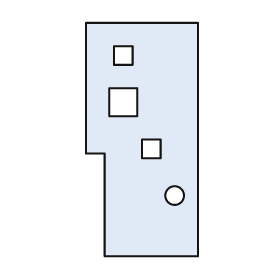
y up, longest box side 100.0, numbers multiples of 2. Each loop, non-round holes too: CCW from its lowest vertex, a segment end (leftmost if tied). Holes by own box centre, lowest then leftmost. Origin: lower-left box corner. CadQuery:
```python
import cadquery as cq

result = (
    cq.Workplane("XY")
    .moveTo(8.0, 0.0)
    .lineTo(48.0, 0.0)
    .lineTo(48.0, 100.0)
    .lineTo(0.0, 100.0)
    .lineTo(0.0, 44.0)
    .lineTo(8.0, 44.0)
    .close()
    .moveTo(38.0, 26.0)
    .circle(4.0)
    .moveTo(24.0, 42.0)
    .lineTo(32.0, 42.0)
    .lineTo(32.0, 50.0)
    .lineTo(24.0, 50.0)
    .close()
    .moveTo(10.0, 60.0)
    .lineTo(22.0, 60.0)
    .lineTo(22.0, 72.0)
    .lineTo(10.0, 72.0)
    .close()
    .moveTo(12.0, 82.0)
    .lineTo(20.0, 82.0)
    .lineTo(20.0, 90.0)
    .lineTo(12.0, 90.0)
    .close()
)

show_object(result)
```